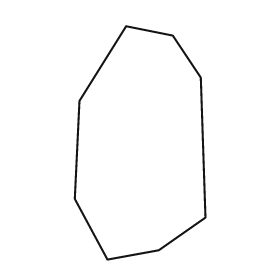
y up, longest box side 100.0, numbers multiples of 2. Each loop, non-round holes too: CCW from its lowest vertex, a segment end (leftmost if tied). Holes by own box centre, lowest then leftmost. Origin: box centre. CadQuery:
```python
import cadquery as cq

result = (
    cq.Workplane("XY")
    .moveTo(-14.0, -50.0)
    .lineTo(8.0, -46.0)
    .lineTo(28.0, -32.0)
    .lineTo(26.0, 28.0)
    .lineTo(14.0, 46.0)
    .lineTo(-6.0, 50.0)
    .lineTo(-26.0, 18.0)
    .lineTo(-28.0, -24.0)
    .close()
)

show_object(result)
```